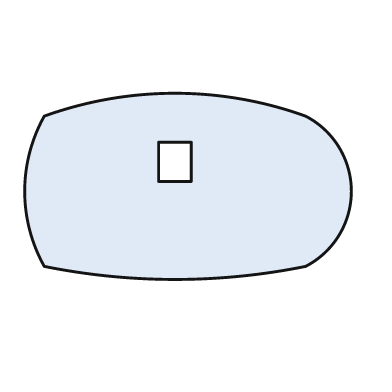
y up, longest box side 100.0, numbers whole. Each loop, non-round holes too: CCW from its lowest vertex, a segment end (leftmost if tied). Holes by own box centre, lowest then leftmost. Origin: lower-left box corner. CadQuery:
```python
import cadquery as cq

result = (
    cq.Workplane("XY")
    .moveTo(6.0, 4.0)
    .threePointArc((46.0, 0.0), (86.0, 4.0))
    .threePointArc((100.0, 27.0), (86.0, 50.0))
    .threePointArc((46.0, 57.0), (6.0, 50.0))
    .threePointArc((0.0, 27.0), (6.0, 4.0))
    .close()
    .moveTo(41.0, 30.0)
    .lineTo(51.0, 30.0)
    .lineTo(51.0, 42.0)
    .lineTo(41.0, 42.0)
    .close()
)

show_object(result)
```